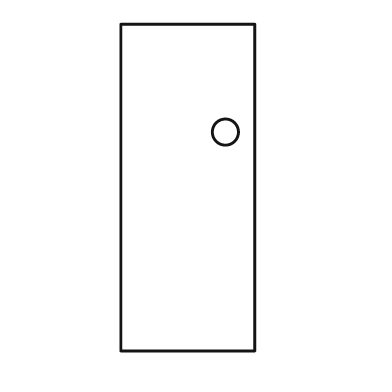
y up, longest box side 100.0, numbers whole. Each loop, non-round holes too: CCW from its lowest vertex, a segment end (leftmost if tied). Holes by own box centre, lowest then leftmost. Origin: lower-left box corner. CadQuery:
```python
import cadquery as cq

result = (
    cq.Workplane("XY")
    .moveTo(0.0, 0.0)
    .lineTo(41.0, 0.0)
    .lineTo(41.0, 100.0)
    .lineTo(0.0, 100.0)
    .close()
    .moveTo(32.0, 67.0)
    .circle(4.0)
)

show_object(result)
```